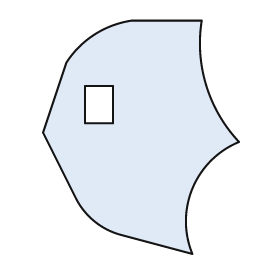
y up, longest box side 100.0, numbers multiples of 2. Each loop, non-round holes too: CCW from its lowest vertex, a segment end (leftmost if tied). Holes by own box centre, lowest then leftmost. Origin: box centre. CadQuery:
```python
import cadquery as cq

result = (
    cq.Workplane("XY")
    .moveTo(22.0, -50.0)
    .threePointArc((22.0, -22.0), (42.0, -2.0))
    .threePointArc((28.0, 22.0), (26.0, 50.0))
    .lineTo(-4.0, 50.0)
    .threePointArc((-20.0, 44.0), (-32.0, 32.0))
    .lineTo(-42.0, 2.0)
    .lineTo(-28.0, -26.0)
    .threePointArc((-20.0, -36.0), (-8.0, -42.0))
    .close()
    .moveTo(-24.0, 6.0)
    .lineTo(-12.0, 6.0)
    .lineTo(-12.0, 22.0)
    .lineTo(-24.0, 22.0)
    .close()
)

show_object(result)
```